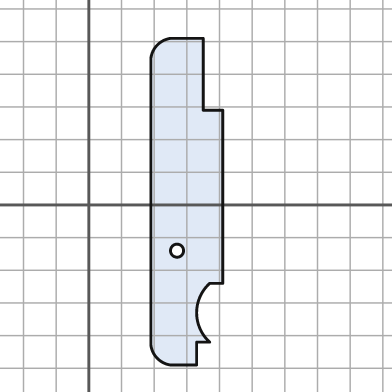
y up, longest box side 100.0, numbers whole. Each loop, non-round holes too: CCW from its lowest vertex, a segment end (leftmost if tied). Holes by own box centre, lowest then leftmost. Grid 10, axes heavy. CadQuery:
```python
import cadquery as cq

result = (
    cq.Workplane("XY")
    .moveTo(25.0, -49.0)
    .lineTo(33.0, -49.0)
    .lineTo(33.0, -42.0)
    .lineTo(37.0, -42.0)
    .threePointArc((33.0, -33.0), (37.0, -24.0))
    .lineTo(41.0, -24.0)
    .lineTo(41.0, 29.0)
    .lineTo(35.0, 29.0)
    .lineTo(35.0, 51.0)
    .lineTo(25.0, 51.0)
    .threePointArc((21.0, 49.0), (19.0, 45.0))
    .lineTo(19.0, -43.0)
    .threePointArc((21.0, -47.0), (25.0, -49.0))
    .close()
    .moveTo(27.0, -14.0)
    .circle(2.0)
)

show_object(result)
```